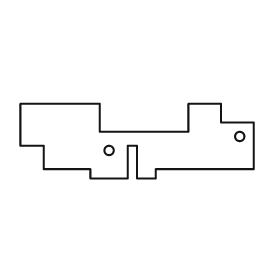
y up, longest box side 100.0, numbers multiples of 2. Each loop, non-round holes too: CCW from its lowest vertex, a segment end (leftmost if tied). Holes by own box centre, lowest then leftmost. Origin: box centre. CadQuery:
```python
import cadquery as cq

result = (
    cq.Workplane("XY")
    .moveTo(-20.0, -16.0)
    .lineTo(-4.0, -16.0)
    .lineTo(-4.0, -2.0)
    .lineTo(0.0, -2.0)
    .lineTo(0.0, -16.0)
    .lineTo(8.0, -16.0)
    .lineTo(8.0, -12.0)
    .lineTo(50.0, -12.0)
    .lineTo(50.0, 8.0)
    .lineTo(36.0, 8.0)
    .lineTo(36.0, 16.0)
    .lineTo(22.0, 16.0)
    .lineTo(22.0, 4.0)
    .lineTo(-16.0, 4.0)
    .lineTo(-16.0, 16.0)
    .lineTo(-50.0, 16.0)
    .lineTo(-50.0, -2.0)
    .lineTo(-40.0, -2.0)
    .lineTo(-40.0, -12.0)
    .lineTo(-20.0, -12.0)
    .close()
    .moveTo(-12.0, -4.0)
    .circle(2.0)
    .moveTo(44.0, 2.0)
    .circle(2.0)
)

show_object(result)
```